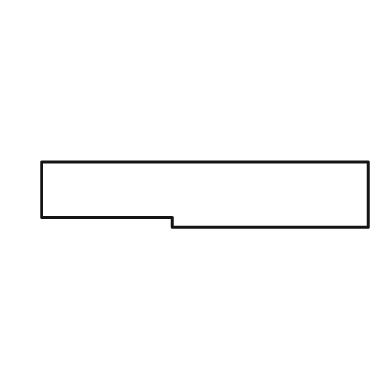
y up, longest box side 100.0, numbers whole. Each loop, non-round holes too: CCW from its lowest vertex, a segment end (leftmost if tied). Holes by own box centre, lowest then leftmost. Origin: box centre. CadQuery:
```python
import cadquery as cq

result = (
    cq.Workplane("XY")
    .moveTo(-10.0, -10.0)
    .lineTo(50.0, -10.0)
    .lineTo(50.0, 10.0)
    .lineTo(-50.0, 10.0)
    .lineTo(-50.0, -7.0)
    .lineTo(-10.0, -7.0)
    .close()
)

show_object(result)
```